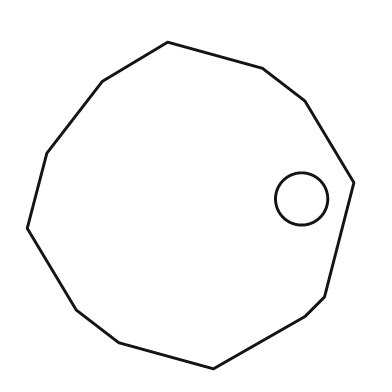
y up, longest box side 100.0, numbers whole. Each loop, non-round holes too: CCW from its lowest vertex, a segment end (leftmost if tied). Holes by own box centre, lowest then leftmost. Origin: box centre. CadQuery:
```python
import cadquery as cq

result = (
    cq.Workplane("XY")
    .moveTo(7.0, -50.0)
    .lineTo(35.0, -34.0)
    .lineTo(41.0, -28.0)
    .lineTo(50.0, 7.0)
    .lineTo(35.0, 32.0)
    .lineTo(22.0, 42.0)
    .lineTo(-7.0, 50.0)
    .lineTo(-27.0, 38.0)
    .lineTo(-44.0, 16.0)
    .lineTo(-50.0, -7.0)
    .lineTo(-35.0, -32.0)
    .lineTo(-22.0, -42.0)
    .close()
    .moveTo(34.0, 2.0)
    .circle(8.0)
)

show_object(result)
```